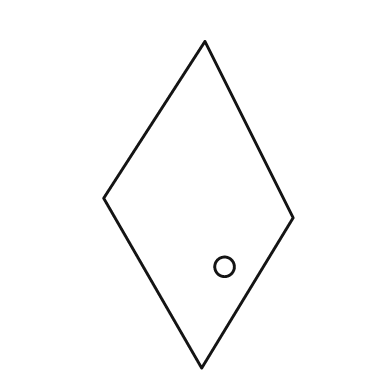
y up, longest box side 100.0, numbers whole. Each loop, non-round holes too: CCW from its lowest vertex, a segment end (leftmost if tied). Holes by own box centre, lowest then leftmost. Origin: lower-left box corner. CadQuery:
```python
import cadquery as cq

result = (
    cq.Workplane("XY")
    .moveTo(30.0, 0.0)
    .lineTo(58.0, 46.0)
    .lineTo(31.0, 100.0)
    .lineTo(0.0, 52.0)
    .close()
    .moveTo(37.0, 31.0)
    .circle(3.0)
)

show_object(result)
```